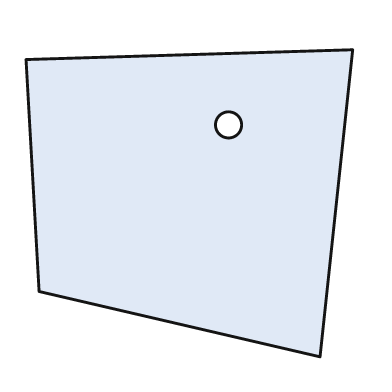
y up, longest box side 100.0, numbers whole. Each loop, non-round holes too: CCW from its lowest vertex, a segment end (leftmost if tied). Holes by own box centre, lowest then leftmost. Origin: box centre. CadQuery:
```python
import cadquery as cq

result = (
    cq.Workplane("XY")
    .moveTo(40.0, -47.0)
    .lineTo(50.0, 47.0)
    .lineTo(-50.0, 44.0)
    .lineTo(-46.0, -27.0)
    .close()
    .moveTo(12.0, 24.0)
    .circle(4.0)
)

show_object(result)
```